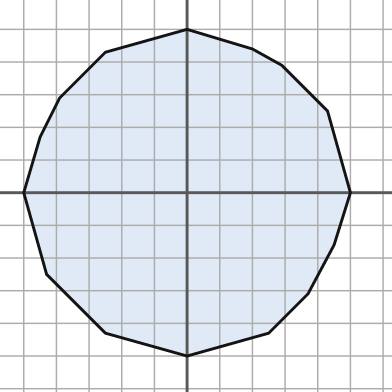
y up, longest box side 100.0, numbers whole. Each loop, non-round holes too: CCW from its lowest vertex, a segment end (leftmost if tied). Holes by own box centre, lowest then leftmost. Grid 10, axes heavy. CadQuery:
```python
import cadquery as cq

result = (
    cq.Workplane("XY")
    .moveTo(0.0, -50.0)
    .lineTo(25.0, -43.0)
    .lineTo(37.0, -31.0)
    .lineTo(45.0, -16.0)
    .lineTo(50.0, 0.0)
    .lineTo(43.0, 25.0)
    .lineTo(29.0, 39.0)
    .lineTo(20.0, 44.0)
    .lineTo(0.0, 50.0)
    .lineTo(-25.0, 43.0)
    .lineTo(-39.0, 29.0)
    .lineTo(-45.0, 17.0)
    .lineTo(-50.0, 0.0)
    .lineTo(-43.0, -25.0)
    .lineTo(-25.0, -43.0)
    .close()
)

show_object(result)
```